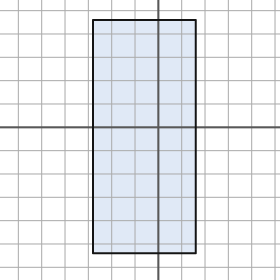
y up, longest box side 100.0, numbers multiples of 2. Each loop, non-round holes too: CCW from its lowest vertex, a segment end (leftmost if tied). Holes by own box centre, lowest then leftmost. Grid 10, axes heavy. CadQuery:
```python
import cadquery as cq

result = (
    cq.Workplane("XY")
    .moveTo(-28.0, -54.0)
    .lineTo(16.0, -54.0)
    .lineTo(16.0, 46.0)
    .lineTo(-28.0, 46.0)
    .close()
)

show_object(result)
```